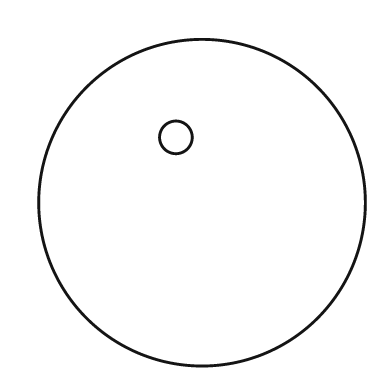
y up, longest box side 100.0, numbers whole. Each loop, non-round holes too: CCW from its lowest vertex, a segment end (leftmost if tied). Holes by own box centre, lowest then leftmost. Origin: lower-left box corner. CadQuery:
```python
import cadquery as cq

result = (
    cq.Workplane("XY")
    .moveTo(50.0, 50.0)
    .circle(50.0)
    .moveTo(42.0, 70.0)
    .circle(5.0)
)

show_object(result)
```